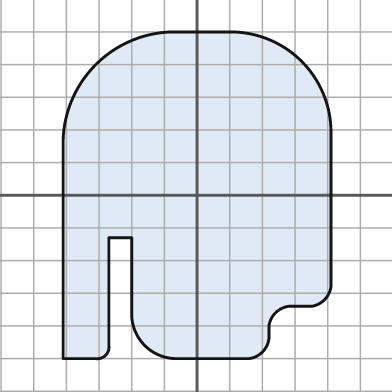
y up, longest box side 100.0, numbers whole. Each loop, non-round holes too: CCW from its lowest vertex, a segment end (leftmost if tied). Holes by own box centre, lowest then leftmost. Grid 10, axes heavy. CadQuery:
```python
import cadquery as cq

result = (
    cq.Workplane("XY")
    .moveTo(-41.0, -50.0)
    .lineTo(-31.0, -50.0)
    .threePointArc((-28.0, -49.0), (-27.0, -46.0))
    .lineTo(-27.0, -13.0)
    .lineTo(-20.0, -13.0)
    .lineTo(-20.0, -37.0)
    .threePointArc((-16.0, -46.0), (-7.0, -50.0))
    .lineTo(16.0, -50.0)
    .threePointArc((20.0, -48.0), (22.0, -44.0))
    .lineTo(22.0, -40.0)
    .threePointArc((24.0, -36.0), (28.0, -34.0))
    .lineTo(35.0, -34.0)
    .threePointArc((39.0, -32.0), (41.0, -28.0))
    .lineTo(41.0, 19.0)
    .threePointArc((32.0, 41.0), (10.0, 50.0))
    .lineTo(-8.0, 50.0)
    .threePointArc((-31.0, 40.0), (-41.0, 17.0))
    .close()
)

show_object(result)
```